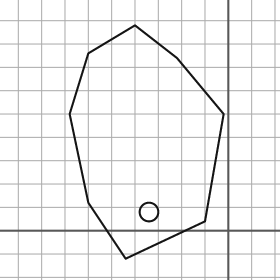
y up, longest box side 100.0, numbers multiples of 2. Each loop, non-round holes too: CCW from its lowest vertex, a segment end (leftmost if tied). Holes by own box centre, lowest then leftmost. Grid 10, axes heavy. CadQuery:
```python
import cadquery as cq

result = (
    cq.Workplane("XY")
    .moveTo(-44.0, -12.0)
    .lineTo(-10.0, 4.0)
    .lineTo(-2.0, 50.0)
    .lineTo(-22.0, 74.0)
    .lineTo(-40.0, 88.0)
    .lineTo(-60.0, 76.0)
    .lineTo(-68.0, 50.0)
    .lineTo(-60.0, 12.0)
    .close()
    .moveTo(-34.0, 8.0)
    .circle(4.0)
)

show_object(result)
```